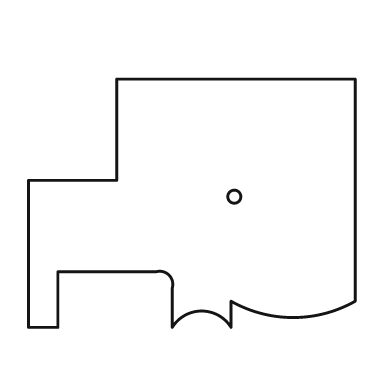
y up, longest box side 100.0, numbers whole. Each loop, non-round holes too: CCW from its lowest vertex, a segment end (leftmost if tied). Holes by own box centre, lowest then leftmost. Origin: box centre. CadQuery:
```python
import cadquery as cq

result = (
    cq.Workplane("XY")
    .moveTo(-50.0, -38.0)
    .lineTo(-41.0, -38.0)
    .lineTo(-41.0, -21.0)
    .lineTo(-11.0, -21.0)
    .threePointArc((-7.0, -22.0), (-6.0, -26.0))
    .lineTo(-6.0, -38.0)
    .threePointArc((3.0, -33.0), (12.0, -38.0))
    .lineTo(12.0, -30.0)
    .threePointArc((31.0, -35.0), (50.0, -30.0))
    .lineTo(50.0, 38.0)
    .lineTo(-23.0, 38.0)
    .lineTo(-23.0, 7.0)
    .lineTo(-50.0, 7.0)
    .close()
    .moveTo(13.0, 2.0)
    .circle(2.0)
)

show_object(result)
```